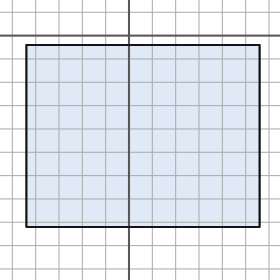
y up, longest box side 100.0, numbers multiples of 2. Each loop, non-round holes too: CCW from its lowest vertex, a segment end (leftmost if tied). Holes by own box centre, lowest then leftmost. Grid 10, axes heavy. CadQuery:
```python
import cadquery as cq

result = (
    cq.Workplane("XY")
    .moveTo(-44.0, -82.0)
    .lineTo(56.0, -82.0)
    .lineTo(56.0, -4.0)
    .lineTo(-44.0, -4.0)
    .close()
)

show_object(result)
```